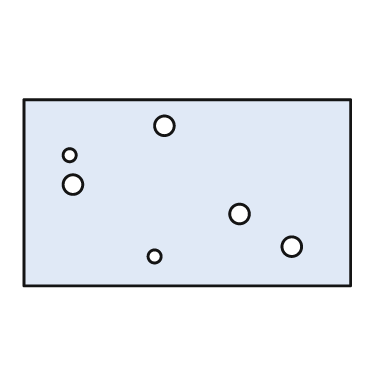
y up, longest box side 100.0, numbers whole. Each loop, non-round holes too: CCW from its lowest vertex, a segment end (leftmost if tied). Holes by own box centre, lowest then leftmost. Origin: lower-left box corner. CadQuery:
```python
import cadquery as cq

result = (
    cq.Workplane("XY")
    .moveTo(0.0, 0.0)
    .lineTo(100.0, 0.0)
    .lineTo(100.0, 57.0)
    .lineTo(0.0, 57.0)
    .close()
    .moveTo(40.0, 9.0)
    .circle(2.0)
    .moveTo(82.0, 12.0)
    .circle(3.0)
    .moveTo(66.0, 22.0)
    .circle(3.0)
    .moveTo(15.0, 31.0)
    .circle(3.0)
    .moveTo(14.0, 40.0)
    .circle(2.0)
    .moveTo(43.0, 49.0)
    .circle(3.0)
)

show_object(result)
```